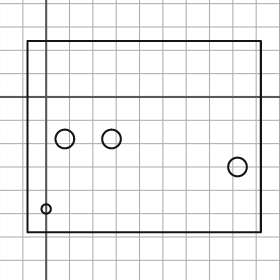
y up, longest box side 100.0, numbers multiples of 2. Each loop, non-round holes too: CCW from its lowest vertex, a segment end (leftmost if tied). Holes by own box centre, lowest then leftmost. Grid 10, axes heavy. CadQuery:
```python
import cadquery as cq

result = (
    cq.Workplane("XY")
    .moveTo(-8.0, -58.0)
    .lineTo(92.0, -58.0)
    .lineTo(92.0, 24.0)
    .lineTo(-8.0, 24.0)
    .close()
    .moveTo(0.0, -48.0)
    .circle(2.0)
    .moveTo(82.0, -30.0)
    .circle(4.0)
    .moveTo(8.0, -18.0)
    .circle(4.0)
    .moveTo(28.0, -18.0)
    .circle(4.0)
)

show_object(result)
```